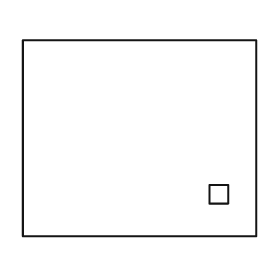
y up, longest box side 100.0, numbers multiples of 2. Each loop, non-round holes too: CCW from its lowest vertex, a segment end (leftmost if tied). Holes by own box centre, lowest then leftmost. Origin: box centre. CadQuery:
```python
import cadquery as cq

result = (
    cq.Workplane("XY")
    .moveTo(-50.0, -42.0)
    .lineTo(50.0, -42.0)
    .lineTo(50.0, 42.0)
    .lineTo(-50.0, 42.0)
    .close()
    .moveTo(30.0, -28.0)
    .lineTo(38.0, -28.0)
    .lineTo(38.0, -20.0)
    .lineTo(30.0, -20.0)
    .close()
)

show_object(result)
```